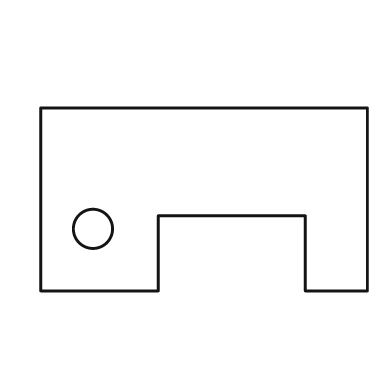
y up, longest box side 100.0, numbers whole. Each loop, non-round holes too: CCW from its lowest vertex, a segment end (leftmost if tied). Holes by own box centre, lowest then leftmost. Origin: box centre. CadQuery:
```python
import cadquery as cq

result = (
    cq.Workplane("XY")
    .moveTo(-50.0, -28.0)
    .lineTo(-14.0, -28.0)
    .lineTo(-14.0, -5.0)
    .lineTo(31.0, -5.0)
    .lineTo(31.0, -28.0)
    .lineTo(50.0, -28.0)
    .lineTo(50.0, 28.0)
    .lineTo(-50.0, 28.0)
    .close()
    .moveTo(-34.0, -9.0)
    .circle(6.0)
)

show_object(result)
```